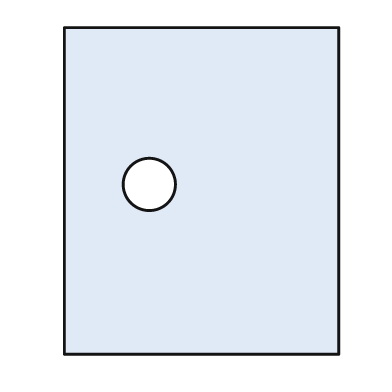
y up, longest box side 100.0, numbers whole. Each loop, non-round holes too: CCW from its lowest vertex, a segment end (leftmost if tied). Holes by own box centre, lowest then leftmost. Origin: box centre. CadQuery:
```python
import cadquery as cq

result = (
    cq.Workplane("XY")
    .moveTo(-42.0, -50.0)
    .lineTo(42.0, -50.0)
    .lineTo(42.0, 50.0)
    .lineTo(-42.0, 50.0)
    .close()
    .moveTo(-16.0, 2.0)
    .circle(8.0)
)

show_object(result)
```